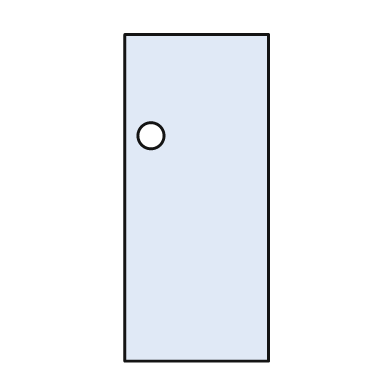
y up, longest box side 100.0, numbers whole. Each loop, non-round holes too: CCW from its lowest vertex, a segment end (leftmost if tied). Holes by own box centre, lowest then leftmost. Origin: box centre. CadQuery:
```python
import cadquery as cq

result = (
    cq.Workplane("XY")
    .moveTo(-22.0, -50.0)
    .lineTo(22.0, -50.0)
    .lineTo(22.0, 50.0)
    .lineTo(-22.0, 50.0)
    .close()
    .moveTo(-14.0, 19.0)
    .circle(4.0)
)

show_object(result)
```